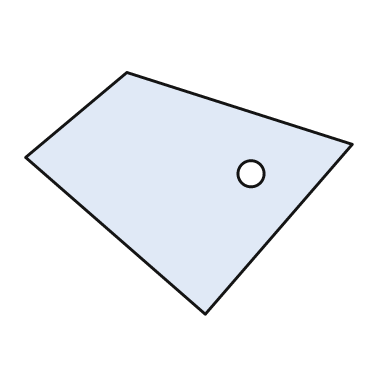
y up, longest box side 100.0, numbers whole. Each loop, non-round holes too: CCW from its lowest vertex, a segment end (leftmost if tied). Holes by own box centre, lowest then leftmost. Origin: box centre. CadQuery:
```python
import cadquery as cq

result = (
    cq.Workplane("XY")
    .moveTo(5.0, -37.0)
    .lineTo(50.0, 15.0)
    .lineTo(-19.0, 37.0)
    .lineTo(-50.0, 11.0)
    .close()
    .moveTo(19.0, 6.0)
    .circle(4.0)
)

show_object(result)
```